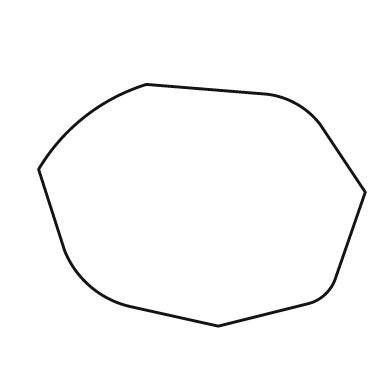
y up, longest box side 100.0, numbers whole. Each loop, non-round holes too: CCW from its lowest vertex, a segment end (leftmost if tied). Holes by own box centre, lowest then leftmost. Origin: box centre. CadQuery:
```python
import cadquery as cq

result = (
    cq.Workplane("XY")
    .moveTo(5.0, -37.0)
    .lineTo(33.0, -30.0)
    .threePointArc((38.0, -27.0), (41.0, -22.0))
    .lineTo(50.0, 4.0)
    .lineTo(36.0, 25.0)
    .threePointArc((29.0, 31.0), (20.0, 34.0))
    .lineTo(-17.0, 37.0)
    .threePointArc((-36.0, 27.0), (-50.0, 11.0))
    .lineTo(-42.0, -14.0)
    .threePointArc((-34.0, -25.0), (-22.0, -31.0))
    .close()
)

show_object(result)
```